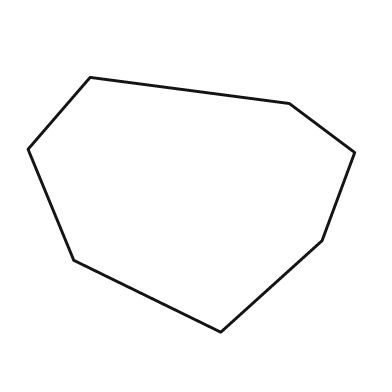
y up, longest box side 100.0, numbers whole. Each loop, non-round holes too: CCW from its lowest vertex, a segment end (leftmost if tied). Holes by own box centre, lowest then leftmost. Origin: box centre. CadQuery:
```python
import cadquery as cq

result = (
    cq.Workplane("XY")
    .moveTo(9.0, -39.0)
    .lineTo(40.0, -11.0)
    .lineTo(50.0, 16.0)
    .lineTo(30.0, 31.0)
    .lineTo(-31.0, 39.0)
    .lineTo(-50.0, 17.0)
    .lineTo(-36.0, -17.0)
    .close()
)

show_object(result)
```